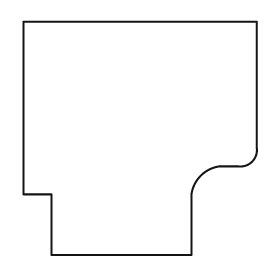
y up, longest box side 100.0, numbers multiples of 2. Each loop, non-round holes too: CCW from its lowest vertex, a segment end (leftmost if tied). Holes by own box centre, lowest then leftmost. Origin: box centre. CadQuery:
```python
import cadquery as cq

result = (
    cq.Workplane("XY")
    .moveTo(-38.0, -50.0)
    .lineTo(22.0, -50.0)
    .lineTo(22.0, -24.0)
    .threePointArc((26.0, -16.0), (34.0, -12.0))
    .lineTo(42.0, -12.0)
    .threePointArc((48.0, -10.0), (50.0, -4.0))
    .lineTo(50.0, 50.0)
    .lineTo(-50.0, 50.0)
    .lineTo(-50.0, -24.0)
    .lineTo(-38.0, -24.0)
    .close()
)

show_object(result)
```